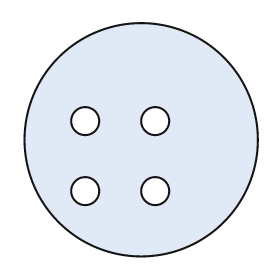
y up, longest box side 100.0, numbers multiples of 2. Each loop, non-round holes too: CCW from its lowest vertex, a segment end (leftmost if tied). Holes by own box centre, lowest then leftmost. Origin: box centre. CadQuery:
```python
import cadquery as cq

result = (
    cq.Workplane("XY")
    .moveTo(0.0, 0.0)
    .circle(50.0)
    .moveTo(-24.0, -22.0)
    .circle(6.0)
    .moveTo(6.0, -22.0)
    .circle(6.0)
    .moveTo(-24.0, 8.0)
    .circle(6.0)
    .moveTo(6.0, 8.0)
    .circle(6.0)
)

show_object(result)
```